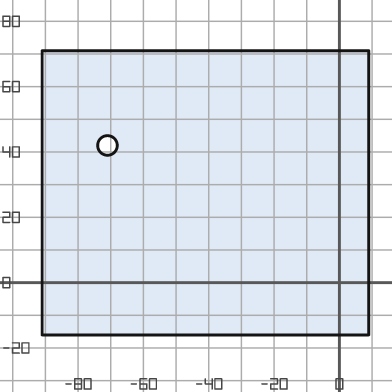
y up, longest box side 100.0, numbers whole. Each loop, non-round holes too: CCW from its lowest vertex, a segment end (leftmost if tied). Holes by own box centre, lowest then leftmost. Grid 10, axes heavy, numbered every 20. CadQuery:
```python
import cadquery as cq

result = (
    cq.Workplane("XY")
    .moveTo(-91.0, -16.0)
    .lineTo(9.0, -16.0)
    .lineTo(9.0, 71.0)
    .lineTo(-91.0, 71.0)
    .close()
    .moveTo(-71.0, 42.0)
    .circle(3.0)
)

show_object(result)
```